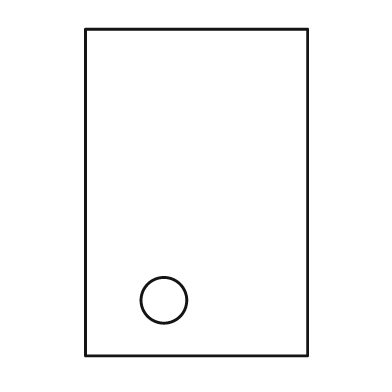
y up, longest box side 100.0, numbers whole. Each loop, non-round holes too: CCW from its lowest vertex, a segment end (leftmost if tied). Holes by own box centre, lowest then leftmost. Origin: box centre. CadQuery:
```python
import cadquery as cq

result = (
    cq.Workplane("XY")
    .moveTo(-34.0, -50.0)
    .lineTo(34.0, -50.0)
    .lineTo(34.0, 50.0)
    .lineTo(-34.0, 50.0)
    .close()
    .moveTo(-10.0, -33.0)
    .circle(7.0)
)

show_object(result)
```